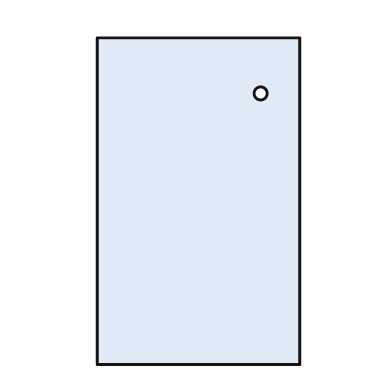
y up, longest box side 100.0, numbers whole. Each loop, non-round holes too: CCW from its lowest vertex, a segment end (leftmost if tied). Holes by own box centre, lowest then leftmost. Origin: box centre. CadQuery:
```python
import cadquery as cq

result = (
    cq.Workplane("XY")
    .moveTo(-31.0, -50.0)
    .lineTo(31.0, -50.0)
    .lineTo(31.0, 50.0)
    .lineTo(-31.0, 50.0)
    .close()
    .moveTo(19.0, 33.0)
    .circle(2.0)
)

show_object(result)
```